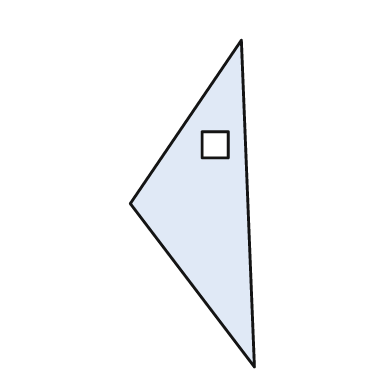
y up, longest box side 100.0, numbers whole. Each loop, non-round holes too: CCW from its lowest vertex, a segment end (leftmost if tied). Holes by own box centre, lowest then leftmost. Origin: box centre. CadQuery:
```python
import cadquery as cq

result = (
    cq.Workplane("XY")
    .moveTo(19.0, -50.0)
    .lineTo(15.0, 50.0)
    .lineTo(-19.0, 0.0)
    .close()
    .moveTo(3.0, 14.0)
    .lineTo(11.0, 14.0)
    .lineTo(11.0, 22.0)
    .lineTo(3.0, 22.0)
    .close()
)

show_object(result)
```